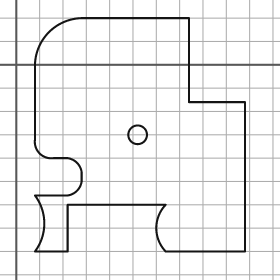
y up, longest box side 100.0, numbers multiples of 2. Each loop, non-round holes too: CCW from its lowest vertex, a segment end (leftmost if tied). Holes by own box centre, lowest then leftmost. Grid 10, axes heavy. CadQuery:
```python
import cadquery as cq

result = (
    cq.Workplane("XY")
    .moveTo(8.0, -80.0)
    .lineTo(22.0, -80.0)
    .lineTo(22.0, -60.0)
    .lineTo(64.0, -60.0)
    .threePointArc((60.0, -70.0), (64.0, -80.0))
    .lineTo(98.0, -80.0)
    .lineTo(98.0, -16.0)
    .lineTo(74.0, -16.0)
    .lineTo(74.0, 20.0)
    .lineTo(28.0, 20.0)
    .threePointArc((14.0, 14.0), (8.0, 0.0))
    .lineTo(8.0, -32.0)
    .threePointArc((10.0, -38.0), (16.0, -40.0))
    .lineTo(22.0, -40.0)
    .threePointArc((26.0, -42.0), (28.0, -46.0))
    .lineTo(28.0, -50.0)
    .threePointArc((26.0, -54.0), (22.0, -56.0))
    .lineTo(8.0, -56.0)
    .threePointArc((12.0, -68.0), (8.0, -80.0))
    .close()
    .moveTo(52.0, -30.0)
    .circle(4.0)
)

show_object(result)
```